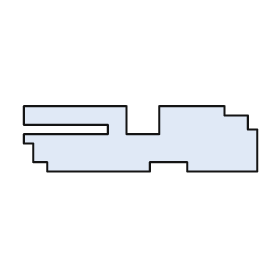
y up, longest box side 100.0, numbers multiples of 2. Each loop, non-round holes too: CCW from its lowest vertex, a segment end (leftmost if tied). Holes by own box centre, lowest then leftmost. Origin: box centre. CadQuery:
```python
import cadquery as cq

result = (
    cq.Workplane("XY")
    .moveTo(-40.0, -14.0)
    .lineTo(4.0, -14.0)
    .lineTo(4.0, -10.0)
    .lineTo(20.0, -10.0)
    .lineTo(20.0, -14.0)
    .lineTo(50.0, -14.0)
    .lineTo(50.0, 4.0)
    .lineTo(46.0, 4.0)
    .lineTo(46.0, 10.0)
    .lineTo(36.0, 10.0)
    .lineTo(36.0, 14.0)
    .lineTo(8.0, 14.0)
    .lineTo(8.0, 2.0)
    .lineTo(-6.0, 2.0)
    .lineTo(-6.0, 14.0)
    .lineTo(-50.0, 14.0)
    .lineTo(-50.0, 6.0)
    .lineTo(-14.0, 6.0)
    .lineTo(-14.0, 2.0)
    .lineTo(-50.0, 2.0)
    .lineTo(-50.0, -2.0)
    .lineTo(-46.0, -2.0)
    .lineTo(-46.0, -10.0)
    .lineTo(-40.0, -10.0)
    .close()
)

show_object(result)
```